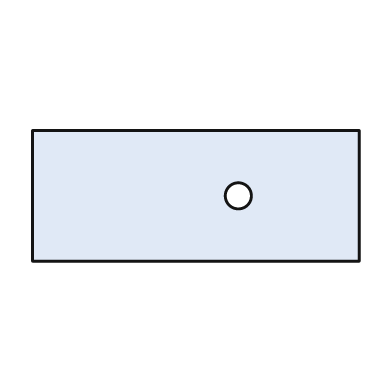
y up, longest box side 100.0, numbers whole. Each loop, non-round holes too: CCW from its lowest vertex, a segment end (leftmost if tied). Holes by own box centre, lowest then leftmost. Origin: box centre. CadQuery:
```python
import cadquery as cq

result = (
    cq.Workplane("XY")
    .moveTo(-50.0, -20.0)
    .lineTo(50.0, -20.0)
    .lineTo(50.0, 20.0)
    .lineTo(-50.0, 20.0)
    .close()
    .moveTo(13.0, 0.0)
    .circle(4.0)
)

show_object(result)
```